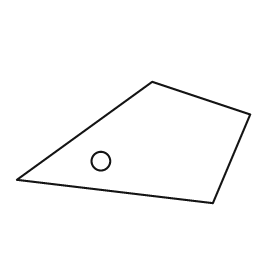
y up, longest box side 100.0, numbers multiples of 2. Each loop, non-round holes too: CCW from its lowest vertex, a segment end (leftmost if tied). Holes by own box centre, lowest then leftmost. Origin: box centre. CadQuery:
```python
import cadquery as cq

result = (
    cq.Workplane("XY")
    .moveTo(34.0, -26.0)
    .lineTo(50.0, 12.0)
    .lineTo(8.0, 26.0)
    .lineTo(-50.0, -16.0)
    .close()
    .moveTo(-14.0, -8.0)
    .circle(4.0)
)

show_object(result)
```